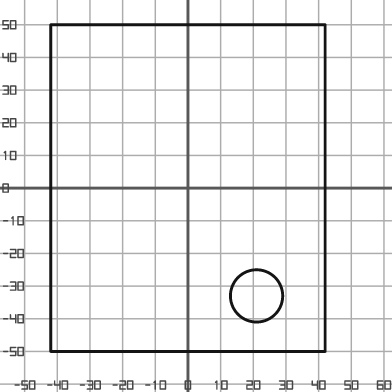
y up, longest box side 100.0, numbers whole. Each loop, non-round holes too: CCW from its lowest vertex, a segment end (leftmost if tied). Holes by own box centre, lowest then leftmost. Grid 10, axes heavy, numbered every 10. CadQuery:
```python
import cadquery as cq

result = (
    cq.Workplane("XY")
    .moveTo(-42.0, -50.0)
    .lineTo(42.0, -50.0)
    .lineTo(42.0, 50.0)
    .lineTo(-42.0, 50.0)
    .close()
    .moveTo(21.0, -33.0)
    .circle(8.0)
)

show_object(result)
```